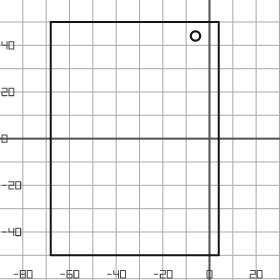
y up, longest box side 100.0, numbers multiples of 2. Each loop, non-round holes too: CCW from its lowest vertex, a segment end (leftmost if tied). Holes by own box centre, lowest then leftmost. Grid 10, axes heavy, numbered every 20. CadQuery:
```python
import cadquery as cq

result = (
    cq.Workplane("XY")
    .moveTo(-68.0, -50.0)
    .lineTo(4.0, -50.0)
    .lineTo(4.0, 50.0)
    .lineTo(-68.0, 50.0)
    .close()
    .moveTo(-6.0, 44.0)
    .circle(2.0)
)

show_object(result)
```